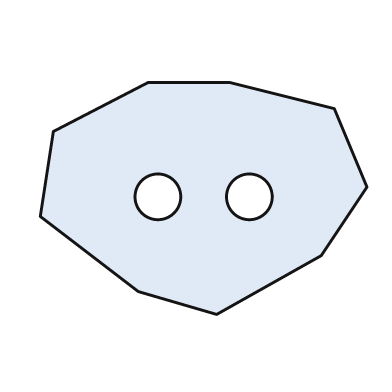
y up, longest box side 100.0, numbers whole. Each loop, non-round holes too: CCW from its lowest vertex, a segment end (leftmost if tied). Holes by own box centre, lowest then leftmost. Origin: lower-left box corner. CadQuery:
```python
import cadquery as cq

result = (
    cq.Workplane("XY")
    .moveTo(54.0, 0.0)
    .lineTo(86.0, 18.0)
    .lineTo(100.0, 39.0)
    .lineTo(90.0, 63.0)
    .lineTo(58.0, 71.0)
    .lineTo(33.0, 71.0)
    .lineTo(4.0, 56.0)
    .lineTo(0.0, 30.0)
    .lineTo(30.0, 7.0)
    .close()
    .moveTo(36.0, 36.0)
    .circle(7.0)
    .moveTo(64.0, 36.0)
    .circle(7.0)
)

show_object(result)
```